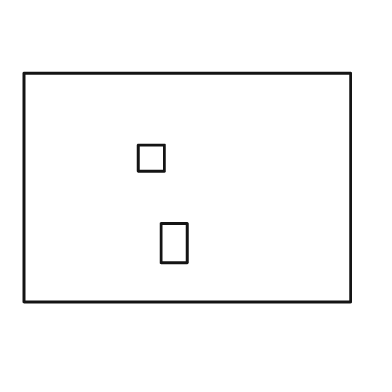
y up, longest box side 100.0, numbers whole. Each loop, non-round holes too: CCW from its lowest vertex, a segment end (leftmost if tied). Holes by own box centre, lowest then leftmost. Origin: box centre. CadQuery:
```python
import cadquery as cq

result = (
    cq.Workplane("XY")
    .moveTo(-50.0, -35.0)
    .lineTo(50.0, -35.0)
    .lineTo(50.0, 35.0)
    .lineTo(-50.0, 35.0)
    .close()
    .moveTo(-8.0, -23.0)
    .lineTo(0.0, -23.0)
    .lineTo(0.0, -11.0)
    .lineTo(-8.0, -11.0)
    .close()
    .moveTo(-15.0, 5.0)
    .lineTo(-7.0, 5.0)
    .lineTo(-7.0, 13.0)
    .lineTo(-15.0, 13.0)
    .close()
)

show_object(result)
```